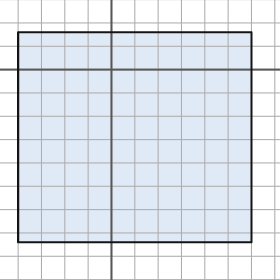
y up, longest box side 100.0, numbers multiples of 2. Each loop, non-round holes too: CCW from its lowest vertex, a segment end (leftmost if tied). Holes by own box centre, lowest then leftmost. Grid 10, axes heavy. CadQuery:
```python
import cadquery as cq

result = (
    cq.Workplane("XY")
    .moveTo(-40.0, -74.0)
    .lineTo(60.0, -74.0)
    .lineTo(60.0, 16.0)
    .lineTo(-40.0, 16.0)
    .close()
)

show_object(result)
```